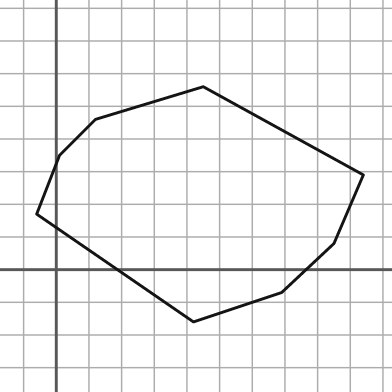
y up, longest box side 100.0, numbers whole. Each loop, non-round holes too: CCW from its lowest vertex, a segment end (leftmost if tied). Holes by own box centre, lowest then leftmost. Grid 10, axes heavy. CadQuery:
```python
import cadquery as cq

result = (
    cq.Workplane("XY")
    .moveTo(42.0, -16.0)
    .lineTo(69.0, -7.0)
    .lineTo(85.0, 8.0)
    .lineTo(94.0, 29.0)
    .lineTo(45.0, 56.0)
    .lineTo(12.0, 46.0)
    .lineTo(1.0, 35.0)
    .lineTo(-6.0, 17.0)
    .close()
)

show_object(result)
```